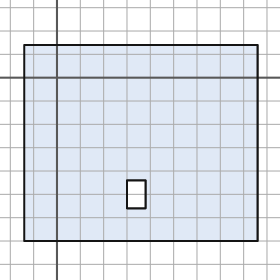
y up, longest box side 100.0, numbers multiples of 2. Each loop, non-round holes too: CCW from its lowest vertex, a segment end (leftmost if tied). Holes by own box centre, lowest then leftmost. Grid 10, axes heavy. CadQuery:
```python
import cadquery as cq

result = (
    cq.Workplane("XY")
    .moveTo(-14.0, -70.0)
    .lineTo(86.0, -70.0)
    .lineTo(86.0, 14.0)
    .lineTo(-14.0, 14.0)
    .close()
    .moveTo(30.0, -56.0)
    .lineTo(38.0, -56.0)
    .lineTo(38.0, -44.0)
    .lineTo(30.0, -44.0)
    .close()
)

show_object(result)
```